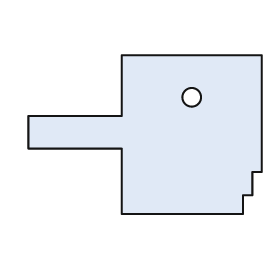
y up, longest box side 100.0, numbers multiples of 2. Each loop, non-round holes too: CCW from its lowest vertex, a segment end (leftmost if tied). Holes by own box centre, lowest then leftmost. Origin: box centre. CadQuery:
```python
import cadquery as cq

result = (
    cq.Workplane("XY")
    .moveTo(-10.0, -34.0)
    .lineTo(42.0, -34.0)
    .lineTo(42.0, -26.0)
    .lineTo(46.0, -26.0)
    .lineTo(46.0, -16.0)
    .lineTo(50.0, -16.0)
    .lineTo(50.0, 34.0)
    .lineTo(-10.0, 34.0)
    .lineTo(-10.0, 8.0)
    .lineTo(-50.0, 8.0)
    .lineTo(-50.0, -6.0)
    .lineTo(-10.0, -6.0)
    .close()
    .moveTo(20.0, 16.0)
    .circle(4.0)
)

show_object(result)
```